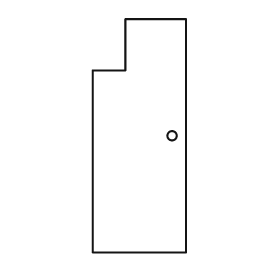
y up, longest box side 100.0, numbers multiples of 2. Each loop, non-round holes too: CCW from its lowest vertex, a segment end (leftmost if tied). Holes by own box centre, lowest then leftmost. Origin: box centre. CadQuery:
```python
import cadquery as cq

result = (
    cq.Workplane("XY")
    .moveTo(-20.0, -50.0)
    .lineTo(20.0, -50.0)
    .lineTo(20.0, 50.0)
    .lineTo(-6.0, 50.0)
    .lineTo(-6.0, 28.0)
    .lineTo(-20.0, 28.0)
    .close()
    .moveTo(14.0, 0.0)
    .circle(2.0)
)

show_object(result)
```